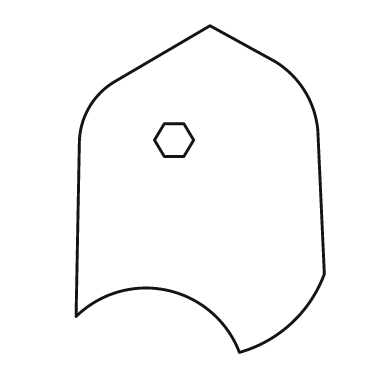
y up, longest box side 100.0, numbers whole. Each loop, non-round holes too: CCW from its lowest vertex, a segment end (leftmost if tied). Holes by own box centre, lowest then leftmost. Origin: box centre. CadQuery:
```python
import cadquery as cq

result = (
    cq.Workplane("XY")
    .moveTo(12.0, -50.0)
    .threePointArc((28.0, -41.0), (38.0, -26.0))
    .lineTo(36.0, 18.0)
    .threePointArc((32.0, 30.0), (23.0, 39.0))
    .lineTo(3.0, 50.0)
    .lineTo(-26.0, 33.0)
    .threePointArc((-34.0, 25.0), (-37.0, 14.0))
    .lineTo(-38.0, -39.0)
    .threePointArc((-10.0, -31.0), (12.0, -50.0))
    .close()
    .moveTo(-11.0, 10.0)
    .lineTo(-5.0, 10.0)
    .lineTo(-2.0, 15.0)
    .lineTo(-5.0, 20.0)
    .lineTo(-11.0, 20.0)
    .lineTo(-14.0, 15.0)
    .close()
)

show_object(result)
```